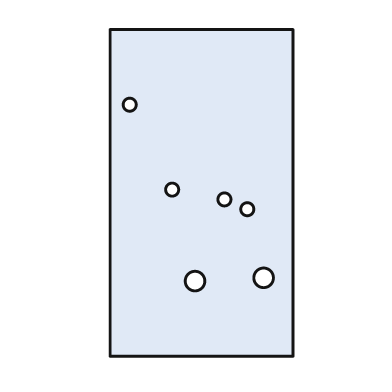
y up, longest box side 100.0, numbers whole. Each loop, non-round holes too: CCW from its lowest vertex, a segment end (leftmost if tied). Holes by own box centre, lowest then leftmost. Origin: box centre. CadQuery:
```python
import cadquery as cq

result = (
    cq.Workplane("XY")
    .moveTo(-28.0, -50.0)
    .lineTo(28.0, -50.0)
    .lineTo(28.0, 50.0)
    .lineTo(-28.0, 50.0)
    .close()
    .moveTo(-2.0, -27.0)
    .circle(3.0)
    .moveTo(19.0, -26.0)
    .circle(3.0)
    .moveTo(14.0, -5.0)
    .circle(2.0)
    .moveTo(7.0, -2.0)
    .circle(2.0)
    .moveTo(-9.0, 1.0)
    .circle(2.0)
    .moveTo(-22.0, 27.0)
    .circle(2.0)
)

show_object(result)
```